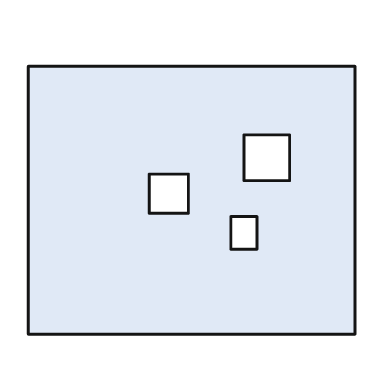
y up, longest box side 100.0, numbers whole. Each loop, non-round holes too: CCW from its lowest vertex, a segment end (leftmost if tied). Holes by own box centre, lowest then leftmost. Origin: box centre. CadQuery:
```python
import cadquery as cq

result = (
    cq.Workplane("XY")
    .moveTo(-50.0, -41.0)
    .lineTo(50.0, -41.0)
    .lineTo(50.0, 41.0)
    .lineTo(-50.0, 41.0)
    .close()
    .moveTo(12.0, -15.0)
    .lineTo(20.0, -15.0)
    .lineTo(20.0, -5.0)
    .lineTo(12.0, -5.0)
    .close()
    .moveTo(-13.0, -4.0)
    .lineTo(-1.0, -4.0)
    .lineTo(-1.0, 8.0)
    .lineTo(-13.0, 8.0)
    .close()
    .moveTo(16.0, 6.0)
    .lineTo(30.0, 6.0)
    .lineTo(30.0, 20.0)
    .lineTo(16.0, 20.0)
    .close()
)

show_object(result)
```